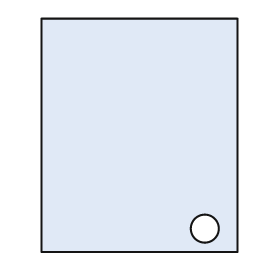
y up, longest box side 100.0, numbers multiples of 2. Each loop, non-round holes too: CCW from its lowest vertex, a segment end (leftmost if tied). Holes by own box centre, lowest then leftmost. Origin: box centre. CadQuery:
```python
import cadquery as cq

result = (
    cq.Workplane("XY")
    .moveTo(-42.0, -50.0)
    .lineTo(42.0, -50.0)
    .lineTo(42.0, 50.0)
    .lineTo(-42.0, 50.0)
    .close()
    .moveTo(28.0, -40.0)
    .circle(6.0)
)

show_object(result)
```